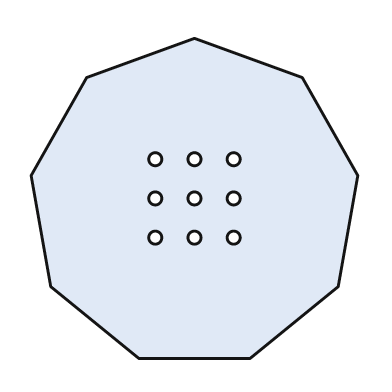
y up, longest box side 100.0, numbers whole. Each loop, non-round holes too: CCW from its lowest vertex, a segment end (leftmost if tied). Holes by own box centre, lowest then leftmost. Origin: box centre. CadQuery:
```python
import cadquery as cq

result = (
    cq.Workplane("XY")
    .moveTo(-17.0, -49.0)
    .lineTo(17.0, -49.0)
    .lineTo(44.0, -27.0)
    .lineTo(50.0, 7.0)
    .lineTo(33.0, 37.0)
    .lineTo(0.0, 49.0)
    .lineTo(-33.0, 37.0)
    .lineTo(-50.0, 7.0)
    .lineTo(-44.0, -27.0)
    .close()
    .moveTo(-12.0, -12.0)
    .circle(2.0)
    .moveTo(0.0, -12.0)
    .circle(2.0)
    .moveTo(12.0, -12.0)
    .circle(2.0)
    .moveTo(-12.0, 0.0)
    .circle(2.0)
    .moveTo(0.0, 0.0)
    .circle(2.0)
    .moveTo(12.0, 0.0)
    .circle(2.0)
    .moveTo(-12.0, 12.0)
    .circle(2.0)
    .moveTo(0.0, 12.0)
    .circle(2.0)
    .moveTo(12.0, 12.0)
    .circle(2.0)
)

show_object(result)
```